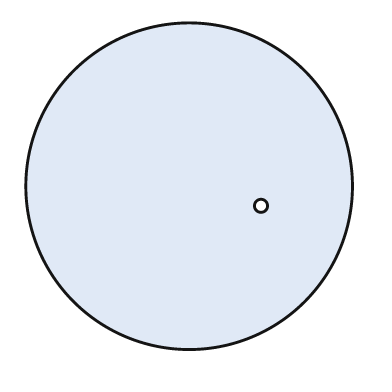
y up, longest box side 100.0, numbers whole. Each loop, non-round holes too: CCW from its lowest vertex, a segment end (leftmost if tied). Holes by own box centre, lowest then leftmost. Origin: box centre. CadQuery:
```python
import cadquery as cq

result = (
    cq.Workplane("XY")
    .moveTo(0.0, 0.0)
    .circle(50.0)
    .moveTo(22.0, -6.0)
    .circle(2.0)
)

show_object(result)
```